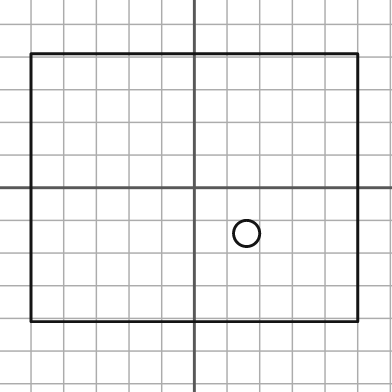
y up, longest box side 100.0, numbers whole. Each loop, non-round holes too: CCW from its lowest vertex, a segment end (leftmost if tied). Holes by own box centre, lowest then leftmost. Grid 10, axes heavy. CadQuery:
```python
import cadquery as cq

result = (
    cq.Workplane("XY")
    .moveTo(-50.0, -41.0)
    .lineTo(50.0, -41.0)
    .lineTo(50.0, 41.0)
    .lineTo(-50.0, 41.0)
    .close()
    .moveTo(16.0, -14.0)
    .circle(4.0)
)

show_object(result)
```